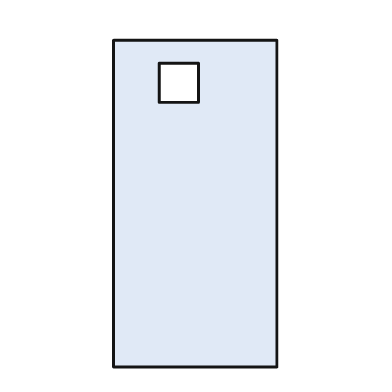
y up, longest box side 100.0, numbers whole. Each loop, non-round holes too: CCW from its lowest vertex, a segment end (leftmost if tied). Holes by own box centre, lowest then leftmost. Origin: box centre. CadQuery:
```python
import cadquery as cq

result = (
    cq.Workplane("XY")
    .moveTo(-25.0, -50.0)
    .lineTo(25.0, -50.0)
    .lineTo(25.0, 50.0)
    .lineTo(-25.0, 50.0)
    .close()
    .moveTo(-11.0, 31.0)
    .lineTo(1.0, 31.0)
    .lineTo(1.0, 43.0)
    .lineTo(-11.0, 43.0)
    .close()
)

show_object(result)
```